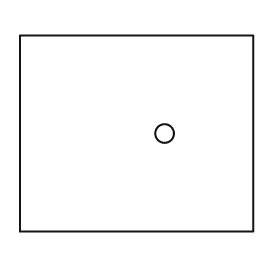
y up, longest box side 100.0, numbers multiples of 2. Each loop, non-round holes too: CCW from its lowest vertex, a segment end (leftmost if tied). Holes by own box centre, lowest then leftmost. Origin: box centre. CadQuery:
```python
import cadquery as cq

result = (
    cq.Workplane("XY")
    .moveTo(-50.0, -42.0)
    .lineTo(50.0, -42.0)
    .lineTo(50.0, 42.0)
    .lineTo(-50.0, 42.0)
    .close()
    .moveTo(12.0, 0.0)
    .circle(4.0)
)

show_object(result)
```